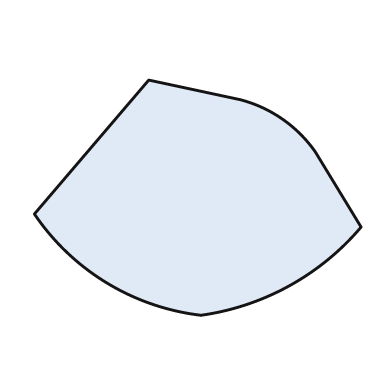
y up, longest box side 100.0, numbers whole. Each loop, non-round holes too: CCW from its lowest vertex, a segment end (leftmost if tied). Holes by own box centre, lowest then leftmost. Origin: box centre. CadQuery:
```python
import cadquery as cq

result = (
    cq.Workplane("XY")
    .moveTo(1.0, -36.0)
    .threePointArc((28.0, -27.0), (50.0, -9.0))
    .lineTo(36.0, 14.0)
    .threePointArc((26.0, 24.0), (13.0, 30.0))
    .lineTo(-15.0, 36.0)
    .lineTo(-50.0, -5.0)
    .threePointArc((-28.0, -26.0), (1.0, -36.0))
    .close()
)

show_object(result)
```